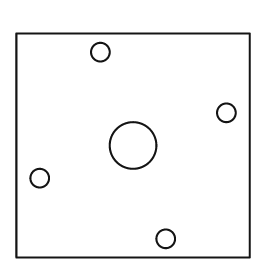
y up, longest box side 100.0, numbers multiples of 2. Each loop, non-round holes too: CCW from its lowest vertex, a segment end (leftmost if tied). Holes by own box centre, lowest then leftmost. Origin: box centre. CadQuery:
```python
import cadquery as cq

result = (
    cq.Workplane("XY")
    .moveTo(-50.0, -48.0)
    .lineTo(50.0, -48.0)
    .lineTo(50.0, 48.0)
    .lineTo(-50.0, 48.0)
    .close()
    .moveTo(14.0, -40.0)
    .circle(4.0)
    .moveTo(-40.0, -14.0)
    .circle(4.0)
    .moveTo(0.0, 0.0)
    .circle(10.0)
    .moveTo(40.0, 14.0)
    .circle(4.0)
    .moveTo(-14.0, 40.0)
    .circle(4.0)
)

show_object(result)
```